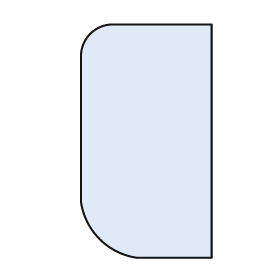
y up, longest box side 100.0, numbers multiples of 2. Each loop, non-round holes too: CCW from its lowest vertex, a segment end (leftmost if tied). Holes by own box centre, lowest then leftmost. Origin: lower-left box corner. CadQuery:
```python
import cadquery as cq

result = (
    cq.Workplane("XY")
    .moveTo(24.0, 0.0)
    .lineTo(56.0, 0.0)
    .lineTo(56.0, 100.0)
    .lineTo(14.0, 100.0)
    .threePointArc((4.0, 96.0), (0.0, 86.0))
    .lineTo(0.0, 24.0)
    .threePointArc((8.0, 8.0), (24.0, 0.0))
    .close()
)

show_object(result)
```